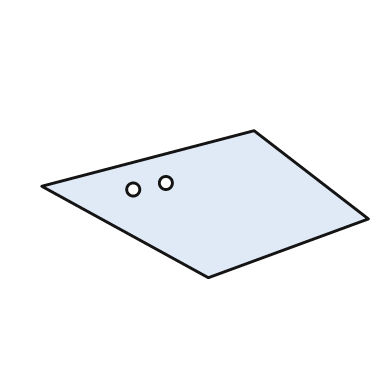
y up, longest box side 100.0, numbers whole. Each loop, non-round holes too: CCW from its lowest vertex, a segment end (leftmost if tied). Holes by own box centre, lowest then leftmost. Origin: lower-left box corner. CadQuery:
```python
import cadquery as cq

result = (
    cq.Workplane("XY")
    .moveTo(51.0, 0.0)
    .lineTo(100.0, 18.0)
    .lineTo(65.0, 45.0)
    .lineTo(0.0, 28.0)
    .close()
    .moveTo(28.0, 27.0)
    .circle(2.0)
    .moveTo(38.0, 29.0)
    .circle(2.0)
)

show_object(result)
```